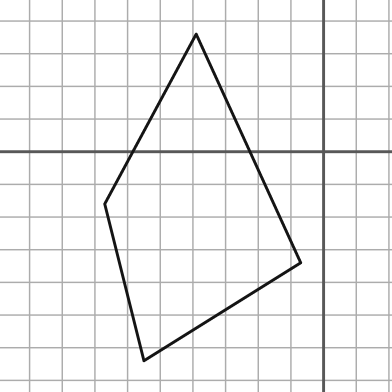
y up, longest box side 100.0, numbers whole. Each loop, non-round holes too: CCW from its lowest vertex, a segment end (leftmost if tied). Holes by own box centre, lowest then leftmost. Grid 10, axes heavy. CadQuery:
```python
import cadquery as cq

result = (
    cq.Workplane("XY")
    .moveTo(-55.0, -64.0)
    .lineTo(-7.0, -34.0)
    .lineTo(-39.0, 36.0)
    .lineTo(-67.0, -16.0)
    .close()
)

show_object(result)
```